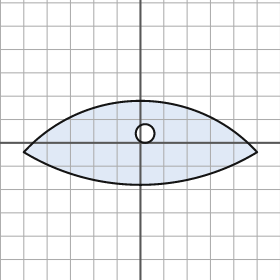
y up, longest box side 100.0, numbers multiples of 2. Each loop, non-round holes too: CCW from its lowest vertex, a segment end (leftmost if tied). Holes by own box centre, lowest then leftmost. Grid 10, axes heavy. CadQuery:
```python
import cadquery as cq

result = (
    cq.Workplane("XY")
    .moveTo(-50.0, -4.0)
    .threePointArc((0.0, -18.0), (50.0, -4.0))
    .threePointArc((0.0, 18.0), (-50.0, -4.0))
    .close()
    .moveTo(2.0, 4.0)
    .circle(4.0)
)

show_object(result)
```